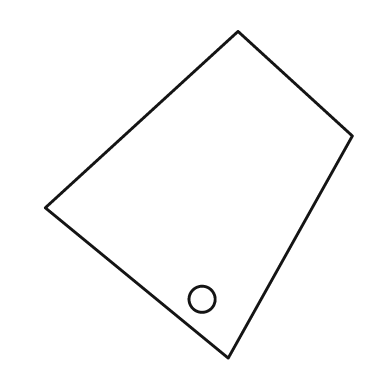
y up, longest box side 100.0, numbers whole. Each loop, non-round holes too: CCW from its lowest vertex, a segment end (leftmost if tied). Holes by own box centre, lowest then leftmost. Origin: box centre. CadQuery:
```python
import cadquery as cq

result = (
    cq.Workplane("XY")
    .moveTo(9.0, -50.0)
    .lineTo(47.0, 18.0)
    .lineTo(12.0, 50.0)
    .lineTo(-47.0, -4.0)
    .close()
    .moveTo(1.0, -32.0)
    .circle(4.0)
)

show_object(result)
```